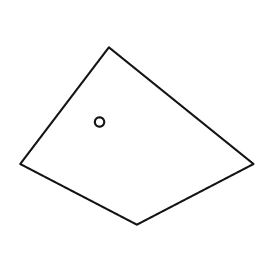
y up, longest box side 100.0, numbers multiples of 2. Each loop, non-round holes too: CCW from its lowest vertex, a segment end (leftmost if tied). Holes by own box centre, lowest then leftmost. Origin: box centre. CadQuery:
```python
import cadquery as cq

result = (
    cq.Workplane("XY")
    .moveTo(0.0, -38.0)
    .lineTo(50.0, -12.0)
    .lineTo(-12.0, 38.0)
    .lineTo(-50.0, -12.0)
    .close()
    .moveTo(-16.0, 6.0)
    .circle(2.0)
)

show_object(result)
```